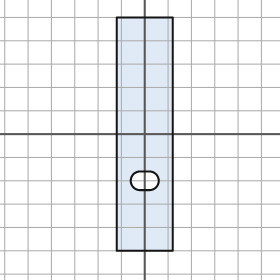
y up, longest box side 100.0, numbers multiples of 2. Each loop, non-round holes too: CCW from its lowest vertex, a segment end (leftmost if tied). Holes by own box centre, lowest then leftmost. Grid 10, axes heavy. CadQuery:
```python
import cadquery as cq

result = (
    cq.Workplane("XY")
    .moveTo(-12.0, -50.0)
    .lineTo(12.0, -50.0)
    .lineTo(12.0, 50.0)
    .lineTo(-12.0, 50.0)
    .close()
    .moveTo(-2.0, -24.0)
    .lineTo(2.0, -24.0)
    .threePointArc((6.0, -20.0), (2.0, -16.0))
    .lineTo(-2.0, -16.0)
    .threePointArc((-6.0, -20.0), (-2.0, -24.0))
    .close()
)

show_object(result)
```